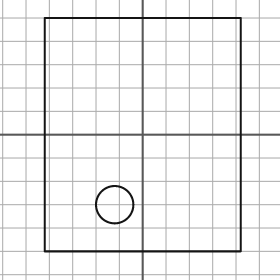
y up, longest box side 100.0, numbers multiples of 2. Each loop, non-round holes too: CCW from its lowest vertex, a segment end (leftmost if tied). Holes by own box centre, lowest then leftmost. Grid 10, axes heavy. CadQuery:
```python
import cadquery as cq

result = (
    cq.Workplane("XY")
    .moveTo(-42.0, -50.0)
    .lineTo(42.0, -50.0)
    .lineTo(42.0, 50.0)
    .lineTo(-42.0, 50.0)
    .close()
    .moveTo(-12.0, -30.0)
    .circle(8.0)
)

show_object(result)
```